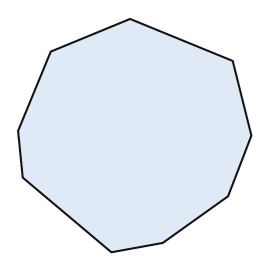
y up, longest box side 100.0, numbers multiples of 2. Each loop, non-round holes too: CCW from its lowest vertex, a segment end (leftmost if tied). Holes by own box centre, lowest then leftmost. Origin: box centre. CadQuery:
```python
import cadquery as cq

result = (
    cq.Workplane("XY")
    .moveTo(-10.0, -50.0)
    .lineTo(12.0, -46.0)
    .lineTo(40.0, -26.0)
    .lineTo(50.0, 0.0)
    .lineTo(42.0, 32.0)
    .lineTo(-2.0, 50.0)
    .lineTo(-36.0, 36.0)
    .lineTo(-50.0, 2.0)
    .lineTo(-48.0, -18.0)
    .close()
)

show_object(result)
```